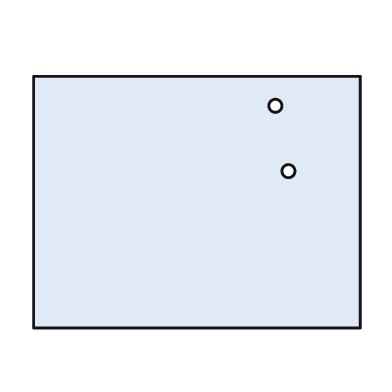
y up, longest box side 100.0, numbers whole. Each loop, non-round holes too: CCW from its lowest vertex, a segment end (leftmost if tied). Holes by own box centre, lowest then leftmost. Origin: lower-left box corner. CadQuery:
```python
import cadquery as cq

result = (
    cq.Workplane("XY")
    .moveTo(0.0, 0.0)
    .lineTo(100.0, 0.0)
    .lineTo(100.0, 77.0)
    .lineTo(0.0, 77.0)
    .close()
    .moveTo(78.0, 48.0)
    .circle(2.0)
    .moveTo(74.0, 68.0)
    .circle(2.0)
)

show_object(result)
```